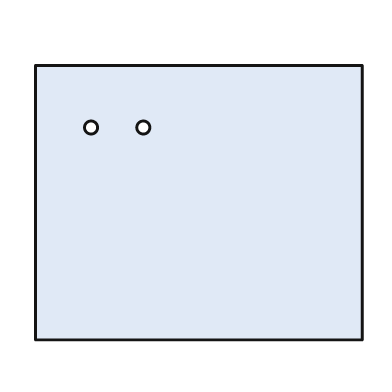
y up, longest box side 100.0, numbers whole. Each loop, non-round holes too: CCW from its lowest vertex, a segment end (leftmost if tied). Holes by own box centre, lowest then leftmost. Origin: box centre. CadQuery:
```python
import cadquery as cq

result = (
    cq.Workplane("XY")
    .moveTo(-50.0, -42.0)
    .lineTo(50.0, -42.0)
    .lineTo(50.0, 42.0)
    .lineTo(-50.0, 42.0)
    .close()
    .moveTo(-33.0, 23.0)
    .circle(2.0)
    .moveTo(-17.0, 23.0)
    .circle(2.0)
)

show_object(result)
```